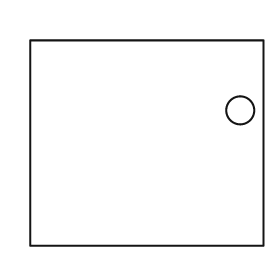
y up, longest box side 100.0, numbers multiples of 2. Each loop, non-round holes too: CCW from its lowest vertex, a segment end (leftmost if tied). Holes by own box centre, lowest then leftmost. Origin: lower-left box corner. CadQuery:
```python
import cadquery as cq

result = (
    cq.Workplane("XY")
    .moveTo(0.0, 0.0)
    .lineTo(100.0, 0.0)
    .lineTo(100.0, 88.0)
    .lineTo(0.0, 88.0)
    .close()
    .moveTo(90.0, 58.0)
    .circle(6.0)
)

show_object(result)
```